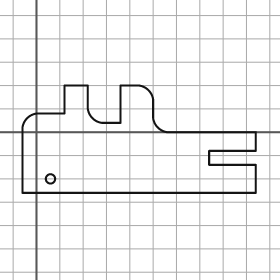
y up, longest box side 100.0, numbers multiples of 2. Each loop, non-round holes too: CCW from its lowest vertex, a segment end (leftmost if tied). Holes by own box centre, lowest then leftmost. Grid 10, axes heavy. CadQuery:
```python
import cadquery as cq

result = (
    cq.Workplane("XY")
    .moveTo(-6.0, -26.0)
    .lineTo(94.0, -26.0)
    .lineTo(94.0, -14.0)
    .lineTo(74.0, -14.0)
    .lineTo(74.0, -8.0)
    .lineTo(94.0, -8.0)
    .lineTo(94.0, 0.0)
    .lineTo(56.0, 0.0)
    .threePointArc((52.0, 2.0), (50.0, 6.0))
    .lineTo(50.0, 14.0)
    .threePointArc((48.0, 18.0), (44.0, 20.0))
    .lineTo(36.0, 20.0)
    .lineTo(36.0, 4.0)
    .lineTo(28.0, 4.0)
    .threePointArc((24.0, 6.0), (22.0, 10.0))
    .lineTo(22.0, 20.0)
    .lineTo(12.0, 20.0)
    .lineTo(12.0, 8.0)
    .lineTo(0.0, 8.0)
    .threePointArc((-4.0, 6.0), (-6.0, 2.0))
    .close()
    .moveTo(6.0, -20.0)
    .circle(2.0)
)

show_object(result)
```